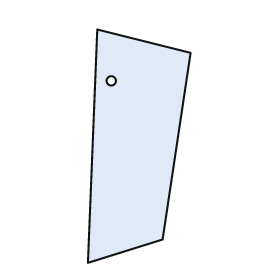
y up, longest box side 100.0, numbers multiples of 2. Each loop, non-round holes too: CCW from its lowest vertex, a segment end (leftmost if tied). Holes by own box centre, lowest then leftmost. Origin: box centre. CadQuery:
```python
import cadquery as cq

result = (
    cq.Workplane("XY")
    .moveTo(-22.0, -50.0)
    .lineTo(10.0, -40.0)
    .lineTo(22.0, 40.0)
    .lineTo(-18.0, 50.0)
    .close()
    .moveTo(-12.0, 28.0)
    .circle(2.0)
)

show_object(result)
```